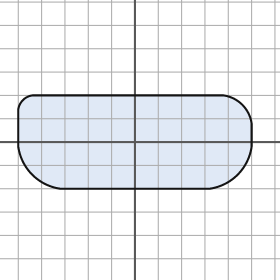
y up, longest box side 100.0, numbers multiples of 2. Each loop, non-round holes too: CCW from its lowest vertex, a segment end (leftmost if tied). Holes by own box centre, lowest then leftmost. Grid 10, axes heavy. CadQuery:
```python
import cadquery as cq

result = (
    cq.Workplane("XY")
    .moveTo(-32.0, -20.0)
    .lineTo(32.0, -20.0)
    .threePointArc((44.0, -14.0), (50.0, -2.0))
    .lineTo(50.0, 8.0)
    .threePointArc((46.0, 16.0), (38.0, 20.0))
    .lineTo(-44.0, 20.0)
    .threePointArc((-48.0, 18.0), (-50.0, 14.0))
    .lineTo(-50.0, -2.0)
    .threePointArc((-44.0, -14.0), (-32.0, -20.0))
    .close()
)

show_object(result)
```